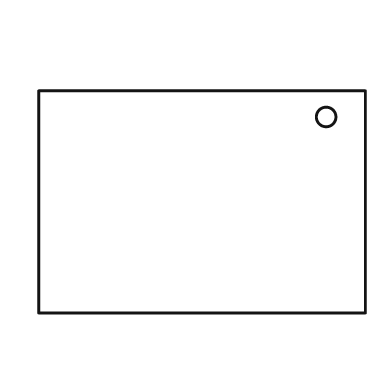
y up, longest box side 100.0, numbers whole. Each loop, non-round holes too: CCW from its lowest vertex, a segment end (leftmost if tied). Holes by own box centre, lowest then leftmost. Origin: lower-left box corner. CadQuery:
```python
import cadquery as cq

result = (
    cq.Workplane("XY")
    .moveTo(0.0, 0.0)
    .lineTo(100.0, 0.0)
    .lineTo(100.0, 68.0)
    .lineTo(0.0, 68.0)
    .close()
    .moveTo(88.0, 60.0)
    .circle(3.0)
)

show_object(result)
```